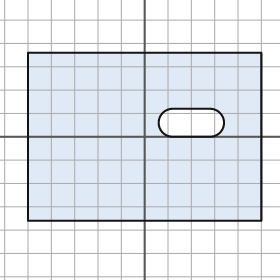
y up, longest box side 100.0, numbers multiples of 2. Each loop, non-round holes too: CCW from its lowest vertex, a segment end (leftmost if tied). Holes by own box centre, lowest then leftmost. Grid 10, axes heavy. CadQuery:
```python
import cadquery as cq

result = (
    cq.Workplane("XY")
    .moveTo(-50.0, -36.0)
    .lineTo(50.0, -36.0)
    .lineTo(50.0, 36.0)
    .lineTo(-50.0, 36.0)
    .close()
    .moveTo(12.0, 0.0)
    .lineTo(28.0, 0.0)
    .threePointArc((34.0, 6.0), (28.0, 12.0))
    .lineTo(12.0, 12.0)
    .threePointArc((6.0, 6.0), (12.0, 0.0))
    .close()
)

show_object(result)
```